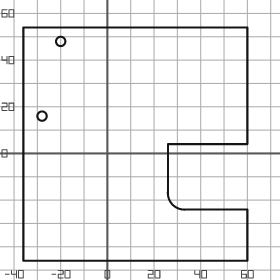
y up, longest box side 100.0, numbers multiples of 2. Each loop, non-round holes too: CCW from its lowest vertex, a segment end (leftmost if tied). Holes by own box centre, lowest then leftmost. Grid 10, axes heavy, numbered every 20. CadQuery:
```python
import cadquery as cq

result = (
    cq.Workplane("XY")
    .moveTo(-36.0, -46.0)
    .lineTo(60.0, -46.0)
    .lineTo(60.0, -24.0)
    .lineTo(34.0, -24.0)
    .threePointArc((28.0, -22.0), (26.0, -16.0))
    .lineTo(26.0, 4.0)
    .lineTo(60.0, 4.0)
    .lineTo(60.0, 54.0)
    .lineTo(-36.0, 54.0)
    .close()
    .moveTo(-28.0, 16.0)
    .circle(2.0)
    .moveTo(-20.0, 48.0)
    .circle(2.0)
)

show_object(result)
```